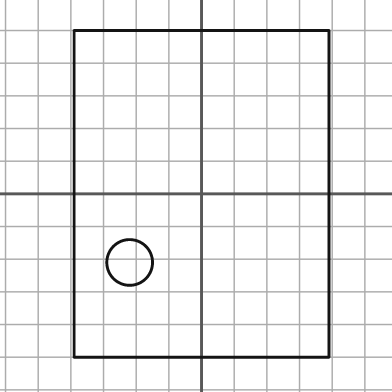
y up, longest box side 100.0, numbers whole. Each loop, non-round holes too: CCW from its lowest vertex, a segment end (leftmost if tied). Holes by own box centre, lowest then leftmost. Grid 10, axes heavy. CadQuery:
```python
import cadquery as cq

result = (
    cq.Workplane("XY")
    .moveTo(-39.0, -50.0)
    .lineTo(39.0, -50.0)
    .lineTo(39.0, 50.0)
    .lineTo(-39.0, 50.0)
    .close()
    .moveTo(-22.0, -21.0)
    .circle(7.0)
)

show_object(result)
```